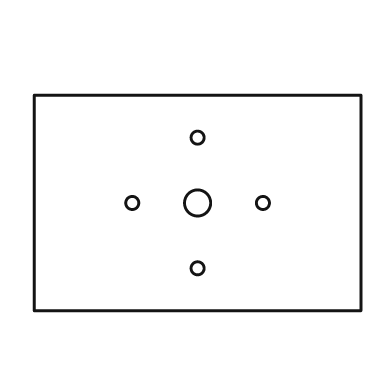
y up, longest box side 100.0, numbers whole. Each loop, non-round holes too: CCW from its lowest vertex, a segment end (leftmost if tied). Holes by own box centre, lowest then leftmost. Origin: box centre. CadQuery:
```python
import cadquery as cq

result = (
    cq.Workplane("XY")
    .moveTo(-50.0, -33.0)
    .lineTo(50.0, -33.0)
    .lineTo(50.0, 33.0)
    .lineTo(-50.0, 33.0)
    .close()
    .moveTo(0.0, -20.0)
    .circle(2.0)
    .moveTo(-20.0, 0.0)
    .circle(2.0)
    .moveTo(0.0, 0.0)
    .circle(4.0)
    .moveTo(20.0, 0.0)
    .circle(2.0)
    .moveTo(0.0, 20.0)
    .circle(2.0)
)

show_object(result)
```